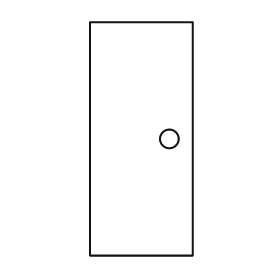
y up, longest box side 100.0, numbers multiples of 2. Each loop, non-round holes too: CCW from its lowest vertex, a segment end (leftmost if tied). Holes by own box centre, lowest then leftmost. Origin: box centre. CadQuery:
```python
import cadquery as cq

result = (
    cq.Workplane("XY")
    .moveTo(-22.0, -50.0)
    .lineTo(22.0, -50.0)
    .lineTo(22.0, 50.0)
    .lineTo(-22.0, 50.0)
    .close()
    .moveTo(12.0, 0.0)
    .circle(4.0)
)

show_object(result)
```